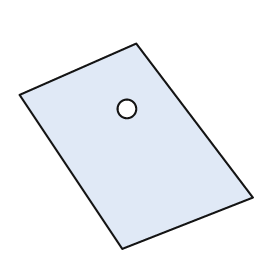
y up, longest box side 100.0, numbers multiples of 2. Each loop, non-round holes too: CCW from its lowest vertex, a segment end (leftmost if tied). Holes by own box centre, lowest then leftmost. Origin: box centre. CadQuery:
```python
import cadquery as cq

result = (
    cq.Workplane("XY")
    .moveTo(-6.0, -44.0)
    .lineTo(50.0, -22.0)
    .lineTo(0.0, 44.0)
    .lineTo(-50.0, 22.0)
    .close()
    .moveTo(-4.0, 16.0)
    .circle(4.0)
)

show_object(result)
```